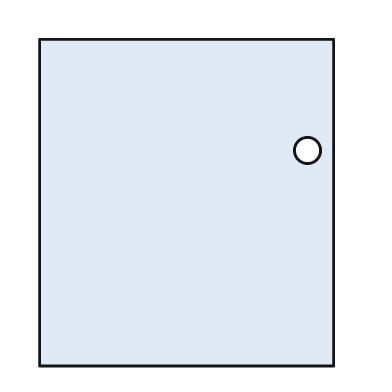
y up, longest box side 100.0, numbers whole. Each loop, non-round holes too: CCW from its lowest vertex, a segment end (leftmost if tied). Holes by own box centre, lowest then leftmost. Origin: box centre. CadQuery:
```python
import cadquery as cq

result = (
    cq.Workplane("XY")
    .moveTo(-45.0, -50.0)
    .lineTo(45.0, -50.0)
    .lineTo(45.0, 50.0)
    .lineTo(-45.0, 50.0)
    .close()
    .moveTo(37.0, 16.0)
    .circle(4.0)
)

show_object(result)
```